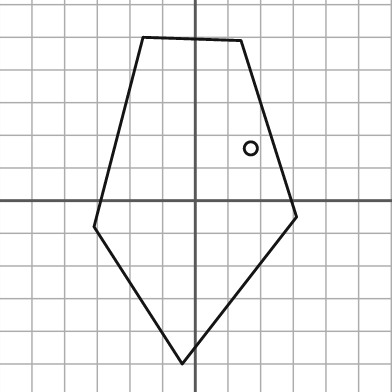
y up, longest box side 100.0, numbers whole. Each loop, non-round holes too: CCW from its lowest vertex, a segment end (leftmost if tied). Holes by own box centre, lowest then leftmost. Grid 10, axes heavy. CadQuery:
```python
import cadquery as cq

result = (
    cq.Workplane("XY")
    .moveTo(-4.0, -50.0)
    .lineTo(31.0, -5.0)
    .lineTo(14.0, 49.0)
    .lineTo(-16.0, 50.0)
    .lineTo(-31.0, -8.0)
    .close()
    .moveTo(17.0, 16.0)
    .circle(2.0)
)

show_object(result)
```